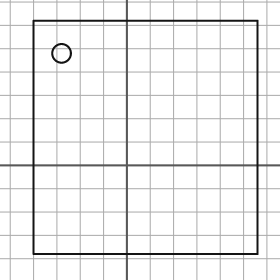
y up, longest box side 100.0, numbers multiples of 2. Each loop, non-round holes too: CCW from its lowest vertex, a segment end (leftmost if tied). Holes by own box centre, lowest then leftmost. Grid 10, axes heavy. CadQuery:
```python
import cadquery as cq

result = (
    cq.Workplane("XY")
    .moveTo(-40.0, -38.0)
    .lineTo(56.0, -38.0)
    .lineTo(56.0, 62.0)
    .lineTo(-40.0, 62.0)
    .close()
    .moveTo(-28.0, 48.0)
    .circle(4.0)
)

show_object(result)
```